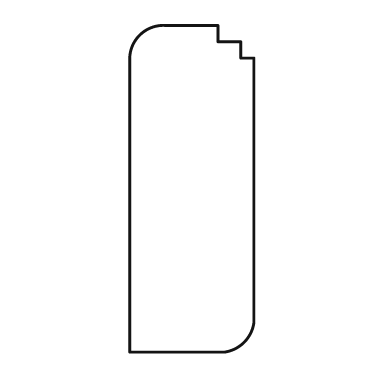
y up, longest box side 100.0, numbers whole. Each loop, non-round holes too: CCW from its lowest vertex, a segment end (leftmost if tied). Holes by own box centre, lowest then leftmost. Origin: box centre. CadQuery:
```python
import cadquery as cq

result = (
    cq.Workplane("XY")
    .moveTo(-19.0, -50.0)
    .lineTo(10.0, -50.0)
    .threePointArc((16.0, -47.0), (19.0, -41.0))
    .lineTo(19.0, 40.0)
    .lineTo(15.0, 40.0)
    .lineTo(15.0, 45.0)
    .lineTo(8.0, 45.0)
    .lineTo(8.0, 50.0)
    .lineTo(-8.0, 50.0)
    .threePointArc((-16.0, 47.0), (-19.0, 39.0))
    .close()
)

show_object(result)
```